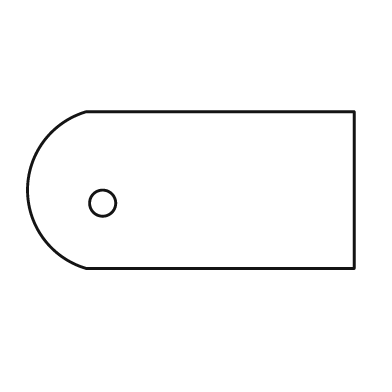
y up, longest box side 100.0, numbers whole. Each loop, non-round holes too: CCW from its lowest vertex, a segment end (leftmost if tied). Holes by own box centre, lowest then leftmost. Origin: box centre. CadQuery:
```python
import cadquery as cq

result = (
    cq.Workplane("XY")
    .moveTo(-32.0, -24.0)
    .lineTo(50.0, -24.0)
    .lineTo(50.0, 24.0)
    .lineTo(-32.0, 24.0)
    .threePointArc((-50.0, 0.0), (-32.0, -24.0))
    .close()
    .moveTo(-27.0, -4.0)
    .circle(4.0)
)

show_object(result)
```